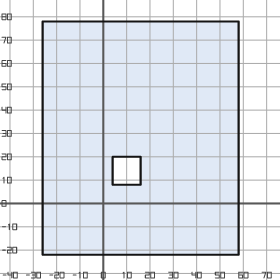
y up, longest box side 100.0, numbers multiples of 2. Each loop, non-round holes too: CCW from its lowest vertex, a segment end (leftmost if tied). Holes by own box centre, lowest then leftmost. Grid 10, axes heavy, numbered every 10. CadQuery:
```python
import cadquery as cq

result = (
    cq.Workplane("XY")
    .moveTo(-26.0, -22.0)
    .lineTo(58.0, -22.0)
    .lineTo(58.0, 78.0)
    .lineTo(-26.0, 78.0)
    .close()
    .moveTo(4.0, 8.0)
    .lineTo(16.0, 8.0)
    .lineTo(16.0, 20.0)
    .lineTo(4.0, 20.0)
    .close()
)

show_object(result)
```